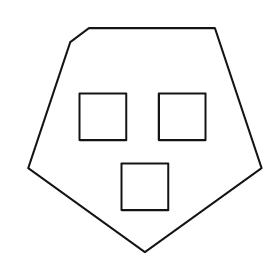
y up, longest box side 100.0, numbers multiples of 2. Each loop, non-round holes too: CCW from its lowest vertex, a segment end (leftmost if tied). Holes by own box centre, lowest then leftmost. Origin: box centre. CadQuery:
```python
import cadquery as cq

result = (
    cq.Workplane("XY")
    .moveTo(0.0, -48.0)
    .lineTo(50.0, -12.0)
    .lineTo(30.0, 48.0)
    .lineTo(-24.0, 48.0)
    .lineTo(-32.0, 42.0)
    .lineTo(-50.0, -12.0)
    .close()
    .moveTo(-10.0, -30.0)
    .lineTo(10.0, -30.0)
    .lineTo(10.0, -10.0)
    .lineTo(-10.0, -10.0)
    .close()
    .moveTo(-28.0, 0.0)
    .lineTo(-8.0, 0.0)
    .lineTo(-8.0, 20.0)
    .lineTo(-28.0, 20.0)
    .close()
    .moveTo(6.0, 0.0)
    .lineTo(26.0, 0.0)
    .lineTo(26.0, 20.0)
    .lineTo(6.0, 20.0)
    .close()
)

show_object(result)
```